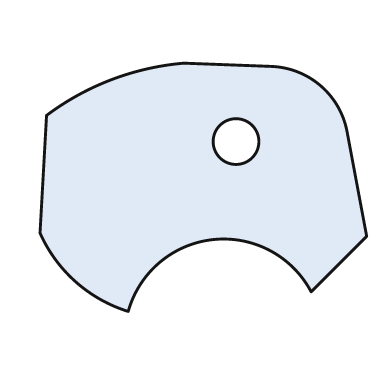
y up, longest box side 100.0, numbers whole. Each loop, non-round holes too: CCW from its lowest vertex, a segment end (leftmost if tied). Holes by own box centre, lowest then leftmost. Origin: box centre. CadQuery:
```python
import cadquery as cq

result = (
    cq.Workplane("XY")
    .moveTo(-23.0, -38.0)
    .threePointArc((3.0, -16.0), (33.0, -32.0))
    .lineTo(50.0, -15.0)
    .lineTo(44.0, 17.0)
    .threePointArc((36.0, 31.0), (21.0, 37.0))
    .lineTo(-6.0, 38.0)
    .threePointArc((-28.0, 33.0), (-48.0, 22.0))
    .lineTo(-50.0, -14.0)
    .threePointArc((-39.0, -29.0), (-23.0, -38.0))
    .close()
    .moveTo(10.0, 14.0)
    .circle(7.0)
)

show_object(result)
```